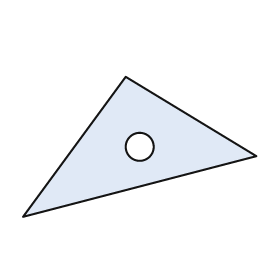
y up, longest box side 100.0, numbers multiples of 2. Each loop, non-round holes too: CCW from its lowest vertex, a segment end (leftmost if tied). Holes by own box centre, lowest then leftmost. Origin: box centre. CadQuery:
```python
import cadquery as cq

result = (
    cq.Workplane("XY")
    .moveTo(-50.0, -30.0)
    .lineTo(50.0, -4.0)
    .lineTo(-6.0, 30.0)
    .close()
    .moveTo(0.0, 0.0)
    .circle(6.0)
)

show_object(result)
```